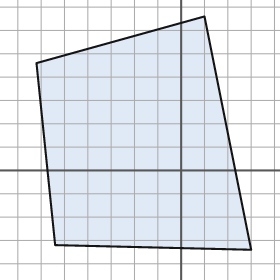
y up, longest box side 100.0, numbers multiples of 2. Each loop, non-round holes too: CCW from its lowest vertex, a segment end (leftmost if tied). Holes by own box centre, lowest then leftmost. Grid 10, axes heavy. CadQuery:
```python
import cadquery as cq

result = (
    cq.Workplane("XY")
    .moveTo(30.0, -34.0)
    .lineTo(10.0, 66.0)
    .lineTo(-62.0, 46.0)
    .lineTo(-54.0, -32.0)
    .close()
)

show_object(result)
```